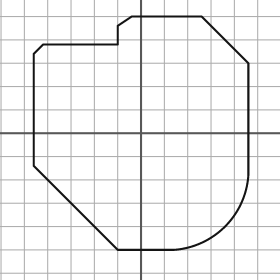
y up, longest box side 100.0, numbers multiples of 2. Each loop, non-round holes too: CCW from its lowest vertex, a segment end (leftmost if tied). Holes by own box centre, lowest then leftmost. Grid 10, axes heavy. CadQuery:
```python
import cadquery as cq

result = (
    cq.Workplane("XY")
    .moveTo(-10.0, -50.0)
    .lineTo(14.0, -50.0)
    .threePointArc((36.0, -40.0), (46.0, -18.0))
    .lineTo(46.0, 30.0)
    .lineTo(26.0, 50.0)
    .lineTo(-4.0, 50.0)
    .lineTo(-10.0, 46.0)
    .lineTo(-10.0, 38.0)
    .lineTo(-42.0, 38.0)
    .lineTo(-46.0, 34.0)
    .lineTo(-46.0, -14.0)
    .close()
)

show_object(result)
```